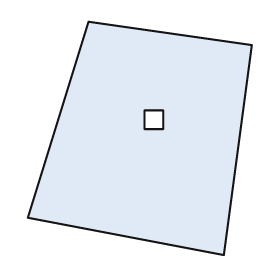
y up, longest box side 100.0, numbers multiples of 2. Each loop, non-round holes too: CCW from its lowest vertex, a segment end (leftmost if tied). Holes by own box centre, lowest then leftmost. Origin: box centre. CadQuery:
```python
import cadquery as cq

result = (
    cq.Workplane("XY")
    .moveTo(36.0, -50.0)
    .lineTo(48.0, 40.0)
    .lineTo(-22.0, 50.0)
    .lineTo(-48.0, -34.0)
    .close()
    .moveTo(2.0, 4.0)
    .lineTo(10.0, 4.0)
    .lineTo(10.0, 12.0)
    .lineTo(2.0, 12.0)
    .close()
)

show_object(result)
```